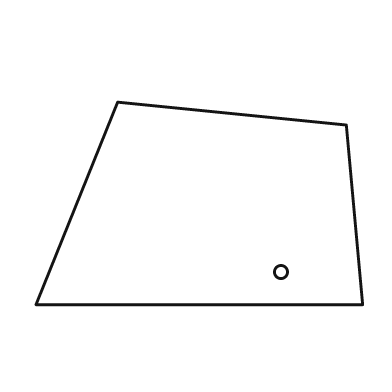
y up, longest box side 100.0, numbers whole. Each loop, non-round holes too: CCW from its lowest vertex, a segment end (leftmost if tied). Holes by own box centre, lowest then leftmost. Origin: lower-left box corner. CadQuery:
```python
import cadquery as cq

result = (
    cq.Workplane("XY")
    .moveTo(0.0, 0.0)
    .lineTo(100.0, 0.0)
    .lineTo(95.0, 55.0)
    .lineTo(25.0, 62.0)
    .close()
    .moveTo(75.0, 10.0)
    .circle(2.0)
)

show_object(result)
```